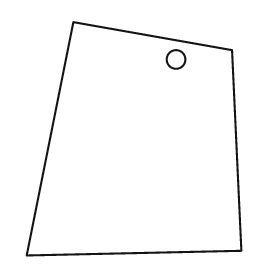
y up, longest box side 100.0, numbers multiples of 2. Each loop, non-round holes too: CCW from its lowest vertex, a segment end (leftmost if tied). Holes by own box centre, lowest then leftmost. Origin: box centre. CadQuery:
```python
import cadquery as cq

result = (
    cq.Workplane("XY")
    .moveTo(-46.0, -50.0)
    .lineTo(46.0, -48.0)
    .lineTo(42.0, 38.0)
    .lineTo(-26.0, 50.0)
    .close()
    .moveTo(18.0, 34.0)
    .circle(4.0)
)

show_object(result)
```